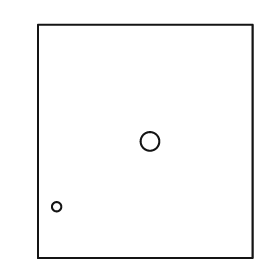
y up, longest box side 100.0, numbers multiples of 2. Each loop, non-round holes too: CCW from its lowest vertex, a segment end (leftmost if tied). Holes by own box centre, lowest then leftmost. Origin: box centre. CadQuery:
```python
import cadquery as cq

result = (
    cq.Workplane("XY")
    .moveTo(-46.0, -50.0)
    .lineTo(46.0, -50.0)
    .lineTo(46.0, 50.0)
    .lineTo(-46.0, 50.0)
    .close()
    .moveTo(-38.0, -28.0)
    .circle(2.0)
    .moveTo(2.0, 0.0)
    .circle(4.0)
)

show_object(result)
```